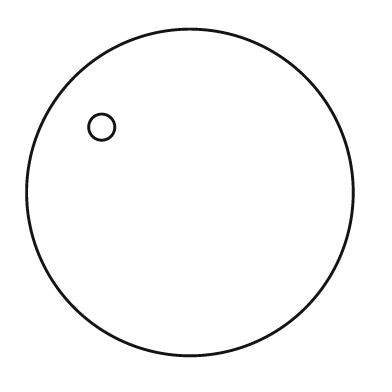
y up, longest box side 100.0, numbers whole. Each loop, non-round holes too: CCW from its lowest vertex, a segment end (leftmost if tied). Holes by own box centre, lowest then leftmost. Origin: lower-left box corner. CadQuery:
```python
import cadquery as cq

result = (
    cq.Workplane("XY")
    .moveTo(50.0, 50.0)
    .circle(50.0)
    .moveTo(23.0, 70.0)
    .circle(4.0)
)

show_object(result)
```